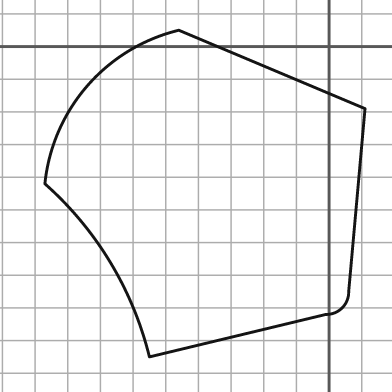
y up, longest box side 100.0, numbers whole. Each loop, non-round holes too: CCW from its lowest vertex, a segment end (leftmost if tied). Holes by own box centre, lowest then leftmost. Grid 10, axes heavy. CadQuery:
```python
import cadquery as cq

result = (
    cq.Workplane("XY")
    .moveTo(-55.0, -95.0)
    .lineTo(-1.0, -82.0)
    .threePointArc((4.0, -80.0), (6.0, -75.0))
    .lineTo(11.0, -19.0)
    .lineTo(-46.0, 5.0)
    .threePointArc((-74.0, -12.0), (-87.0, -42.0))
    .threePointArc((-67.0, -66.0), (-55.0, -95.0))
    .close()
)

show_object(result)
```